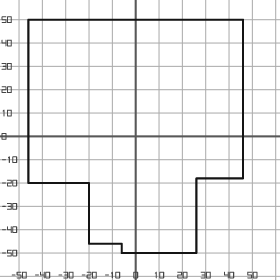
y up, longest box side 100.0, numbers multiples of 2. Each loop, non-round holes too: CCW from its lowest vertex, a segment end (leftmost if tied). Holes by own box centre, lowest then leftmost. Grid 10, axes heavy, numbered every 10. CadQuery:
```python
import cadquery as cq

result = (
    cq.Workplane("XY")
    .moveTo(-6.0, -50.0)
    .lineTo(26.0, -50.0)
    .lineTo(26.0, -18.0)
    .lineTo(46.0, -18.0)
    .lineTo(46.0, 50.0)
    .lineTo(-46.0, 50.0)
    .lineTo(-46.0, -20.0)
    .lineTo(-20.0, -20.0)
    .lineTo(-20.0, -46.0)
    .lineTo(-6.0, -46.0)
    .close()
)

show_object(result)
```